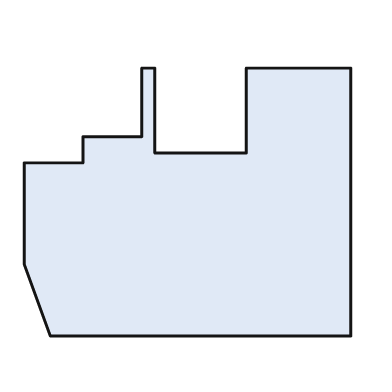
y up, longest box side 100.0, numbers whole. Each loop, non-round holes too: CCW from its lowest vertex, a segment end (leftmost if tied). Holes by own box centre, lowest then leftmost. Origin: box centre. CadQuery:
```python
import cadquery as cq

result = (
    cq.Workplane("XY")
    .moveTo(-42.0, -41.0)
    .lineTo(50.0, -41.0)
    .lineTo(50.0, 41.0)
    .lineTo(18.0, 41.0)
    .lineTo(18.0, 15.0)
    .lineTo(-10.0, 15.0)
    .lineTo(-10.0, 41.0)
    .lineTo(-14.0, 41.0)
    .lineTo(-14.0, 20.0)
    .lineTo(-32.0, 20.0)
    .lineTo(-32.0, 12.0)
    .lineTo(-50.0, 12.0)
    .lineTo(-50.0, -19.0)
    .close()
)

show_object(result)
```